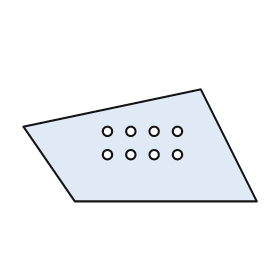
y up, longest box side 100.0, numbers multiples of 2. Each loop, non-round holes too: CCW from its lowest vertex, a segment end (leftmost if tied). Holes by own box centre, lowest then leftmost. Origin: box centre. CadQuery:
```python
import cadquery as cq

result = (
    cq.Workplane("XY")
    .moveTo(-28.0, -24.0)
    .lineTo(50.0, -24.0)
    .lineTo(26.0, 24.0)
    .lineTo(-50.0, 8.0)
    .close()
    .moveTo(-14.0, -4.0)
    .circle(2.0)
    .moveTo(-4.0, -4.0)
    .circle(2.0)
    .moveTo(6.0, -4.0)
    .circle(2.0)
    .moveTo(16.0, -4.0)
    .circle(2.0)
    .moveTo(-14.0, 6.0)
    .circle(2.0)
    .moveTo(-4.0, 6.0)
    .circle(2.0)
    .moveTo(6.0, 6.0)
    .circle(2.0)
    .moveTo(16.0, 6.0)
    .circle(2.0)
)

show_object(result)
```